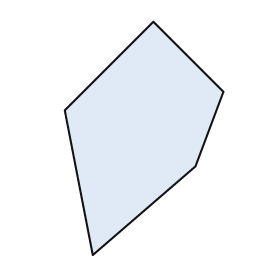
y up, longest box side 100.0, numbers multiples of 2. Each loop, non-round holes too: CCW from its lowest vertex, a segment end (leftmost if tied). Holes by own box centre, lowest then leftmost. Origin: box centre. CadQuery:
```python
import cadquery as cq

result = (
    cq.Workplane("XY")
    .moveTo(-22.0, -50.0)
    .lineTo(22.0, -12.0)
    .lineTo(34.0, 20.0)
    .lineTo(4.0, 50.0)
    .lineTo(-34.0, 12.0)
    .close()
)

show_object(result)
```